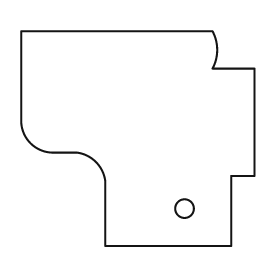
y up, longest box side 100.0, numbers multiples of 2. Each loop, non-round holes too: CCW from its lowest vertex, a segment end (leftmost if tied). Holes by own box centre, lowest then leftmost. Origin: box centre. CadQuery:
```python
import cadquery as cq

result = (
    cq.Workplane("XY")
    .moveTo(-14.0, -46.0)
    .lineTo(40.0, -46.0)
    .lineTo(40.0, -16.0)
    .lineTo(50.0, -16.0)
    .lineTo(50.0, 30.0)
    .lineTo(32.0, 30.0)
    .threePointArc((34.0, 38.0), (32.0, 46.0))
    .lineTo(-50.0, 46.0)
    .lineTo(-50.0, 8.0)
    .threePointArc((-46.0, -2.0), (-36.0, -6.0))
    .lineTo(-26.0, -6.0)
    .threePointArc((-18.0, -10.0), (-14.0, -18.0))
    .close()
    .moveTo(20.0, -30.0)
    .circle(4.0)
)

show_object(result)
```